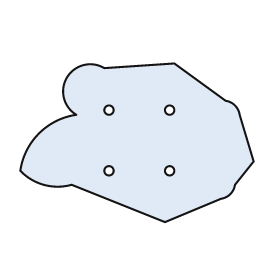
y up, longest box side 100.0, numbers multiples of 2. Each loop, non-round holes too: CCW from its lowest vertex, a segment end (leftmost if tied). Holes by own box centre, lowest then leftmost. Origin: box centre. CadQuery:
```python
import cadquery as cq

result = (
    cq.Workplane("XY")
    .moveTo(12.0, -34.0)
    .lineTo(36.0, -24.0)
    .threePointArc((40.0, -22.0), (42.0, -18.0))
    .lineTo(50.0, -8.0)
    .lineTo(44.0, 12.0)
    .threePointArc((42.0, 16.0), (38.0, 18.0))
    .lineTo(16.0, 34.0)
    .lineTo(-14.0, 32.0)
    .threePointArc((-30.0, 28.0), (-26.0, 12.0))
    .threePointArc((-42.0, 4.0), (-50.0, -12.0))
    .threePointArc((-40.0, -18.0), (-28.0, -18.0))
    .close()
    .moveTo(-12.0, -12.0)
    .circle(2.0)
    .moveTo(14.0, -12.0)
    .circle(2.0)
    .moveTo(-12.0, 14.0)
    .circle(2.0)
    .moveTo(14.0, 14.0)
    .circle(2.0)
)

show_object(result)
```